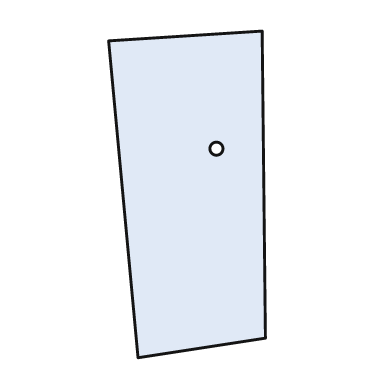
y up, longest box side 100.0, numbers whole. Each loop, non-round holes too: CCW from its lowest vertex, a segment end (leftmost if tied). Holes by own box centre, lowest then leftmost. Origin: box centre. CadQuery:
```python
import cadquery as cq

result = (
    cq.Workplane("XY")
    .moveTo(-15.0, -50.0)
    .lineTo(24.0, -44.0)
    .lineTo(23.0, 50.0)
    .lineTo(-24.0, 47.0)
    .close()
    .moveTo(9.0, 14.0)
    .circle(2.0)
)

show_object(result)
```